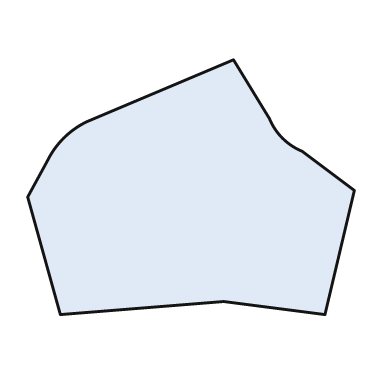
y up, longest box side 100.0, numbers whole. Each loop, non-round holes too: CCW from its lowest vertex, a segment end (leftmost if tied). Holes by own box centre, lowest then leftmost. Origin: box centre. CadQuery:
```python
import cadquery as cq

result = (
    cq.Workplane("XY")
    .moveTo(-40.0, -39.0)
    .lineTo(10.0, -35.0)
    .lineTo(41.0, -39.0)
    .lineTo(50.0, -1.0)
    .lineTo(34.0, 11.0)
    .threePointArc((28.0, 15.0), (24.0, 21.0))
    .lineTo(13.0, 39.0)
    .lineTo(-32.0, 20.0)
    .threePointArc((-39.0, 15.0), (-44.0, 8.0))
    .lineTo(-50.0, -3.0)
    .close()
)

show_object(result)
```